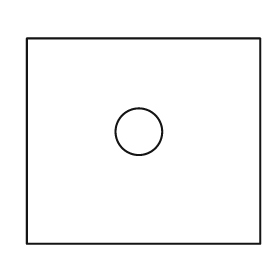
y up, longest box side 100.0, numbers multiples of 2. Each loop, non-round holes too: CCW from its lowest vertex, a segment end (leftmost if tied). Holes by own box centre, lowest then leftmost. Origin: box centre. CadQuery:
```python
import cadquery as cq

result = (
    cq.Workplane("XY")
    .moveTo(-50.0, -44.0)
    .lineTo(50.0, -44.0)
    .lineTo(50.0, 44.0)
    .lineTo(-50.0, 44.0)
    .close()
    .moveTo(-2.0, 4.0)
    .circle(10.0)
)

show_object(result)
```